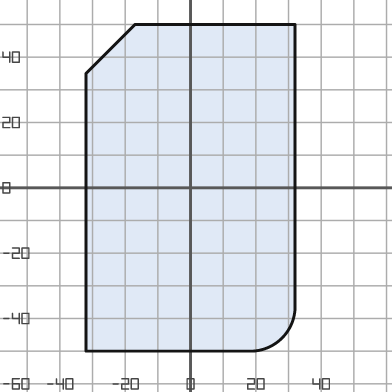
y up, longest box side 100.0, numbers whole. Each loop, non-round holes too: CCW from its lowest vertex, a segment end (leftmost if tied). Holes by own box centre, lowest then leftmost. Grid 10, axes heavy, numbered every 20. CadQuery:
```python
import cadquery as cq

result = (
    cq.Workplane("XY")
    .moveTo(-32.0, -50.0)
    .lineTo(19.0, -50.0)
    .threePointArc((28.0, -46.0), (32.0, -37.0))
    .lineTo(32.0, 50.0)
    .lineTo(-17.0, 50.0)
    .lineTo(-32.0, 35.0)
    .close()
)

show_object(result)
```